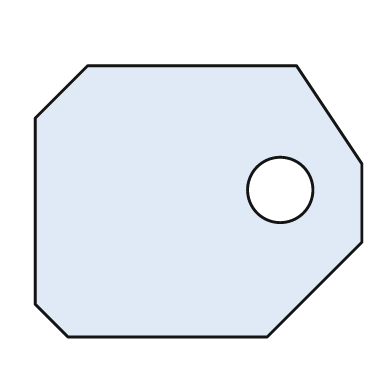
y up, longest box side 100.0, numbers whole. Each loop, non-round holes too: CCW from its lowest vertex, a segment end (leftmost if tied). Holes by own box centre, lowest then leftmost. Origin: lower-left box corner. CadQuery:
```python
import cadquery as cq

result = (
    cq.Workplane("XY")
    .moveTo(10.0, 0.0)
    .lineTo(71.0, 0.0)
    .lineTo(100.0, 29.0)
    .lineTo(100.0, 53.0)
    .lineTo(80.0, 83.0)
    .lineTo(16.0, 83.0)
    .lineTo(0.0, 67.0)
    .lineTo(0.0, 10.0)
    .close()
    .moveTo(75.0, 45.0)
    .circle(10.0)
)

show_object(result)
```